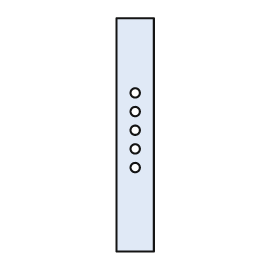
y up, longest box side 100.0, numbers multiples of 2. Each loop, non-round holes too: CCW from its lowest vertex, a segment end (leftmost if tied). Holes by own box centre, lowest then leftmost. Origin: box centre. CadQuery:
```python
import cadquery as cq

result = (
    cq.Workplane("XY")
    .moveTo(-8.0, -50.0)
    .lineTo(8.0, -50.0)
    .lineTo(8.0, 50.0)
    .lineTo(-8.0, 50.0)
    .close()
    .moveTo(0.0, -14.0)
    .circle(2.0)
    .moveTo(0.0, -6.0)
    .circle(2.0)
    .moveTo(0.0, 2.0)
    .circle(2.0)
    .moveTo(0.0, 10.0)
    .circle(2.0)
    .moveTo(0.0, 18.0)
    .circle(2.0)
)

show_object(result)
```